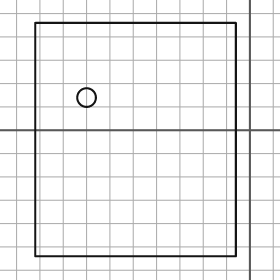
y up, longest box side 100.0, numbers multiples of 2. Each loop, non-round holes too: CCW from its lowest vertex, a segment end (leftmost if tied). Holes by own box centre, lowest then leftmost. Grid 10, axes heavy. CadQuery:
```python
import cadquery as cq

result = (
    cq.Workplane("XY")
    .moveTo(-92.0, -54.0)
    .lineTo(-6.0, -54.0)
    .lineTo(-6.0, 46.0)
    .lineTo(-92.0, 46.0)
    .close()
    .moveTo(-70.0, 14.0)
    .circle(4.0)
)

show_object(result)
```